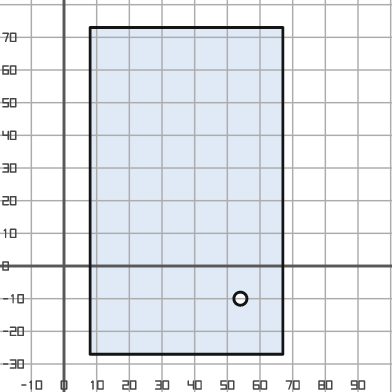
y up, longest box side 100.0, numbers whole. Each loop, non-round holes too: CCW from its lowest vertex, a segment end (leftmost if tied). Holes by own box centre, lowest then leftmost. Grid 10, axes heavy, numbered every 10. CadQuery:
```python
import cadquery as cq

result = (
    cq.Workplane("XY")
    .moveTo(8.0, -27.0)
    .lineTo(67.0, -27.0)
    .lineTo(67.0, 73.0)
    .lineTo(8.0, 73.0)
    .close()
    .moveTo(54.0, -10.0)
    .circle(2.0)
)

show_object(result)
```